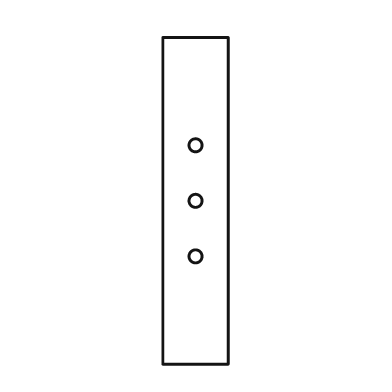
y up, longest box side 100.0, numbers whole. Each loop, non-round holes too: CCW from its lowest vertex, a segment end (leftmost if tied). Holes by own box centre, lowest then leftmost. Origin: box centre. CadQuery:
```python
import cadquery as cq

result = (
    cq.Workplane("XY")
    .moveTo(-10.0, -50.0)
    .lineTo(10.0, -50.0)
    .lineTo(10.0, 50.0)
    .lineTo(-10.0, 50.0)
    .close()
    .moveTo(0.0, -17.0)
    .circle(2.0)
    .moveTo(0.0, 0.0)
    .circle(2.0)
    .moveTo(0.0, 17.0)
    .circle(2.0)
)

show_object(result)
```